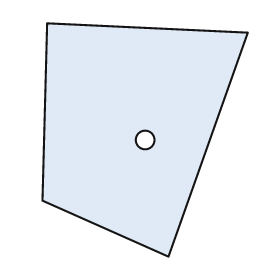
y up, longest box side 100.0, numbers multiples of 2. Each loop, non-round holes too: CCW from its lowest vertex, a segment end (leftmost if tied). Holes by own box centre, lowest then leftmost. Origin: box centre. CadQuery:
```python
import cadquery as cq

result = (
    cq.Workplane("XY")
    .moveTo(10.0, -50.0)
    .lineTo(44.0, 46.0)
    .lineTo(-42.0, 50.0)
    .lineTo(-44.0, -26.0)
    .close()
    .moveTo(0.0, 0.0)
    .circle(4.0)
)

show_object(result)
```